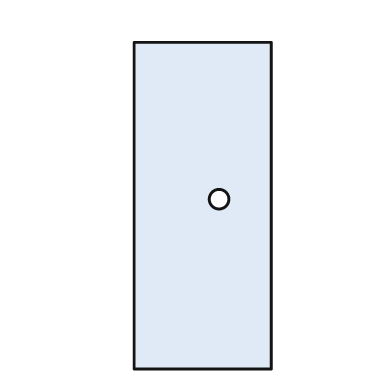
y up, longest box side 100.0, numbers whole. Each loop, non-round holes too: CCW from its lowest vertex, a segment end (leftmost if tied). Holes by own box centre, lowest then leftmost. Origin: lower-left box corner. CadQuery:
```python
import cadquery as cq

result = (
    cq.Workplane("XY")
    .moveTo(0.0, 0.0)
    .lineTo(42.0, 0.0)
    .lineTo(42.0, 100.0)
    .lineTo(0.0, 100.0)
    .close()
    .moveTo(26.0, 52.0)
    .circle(3.0)
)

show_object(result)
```